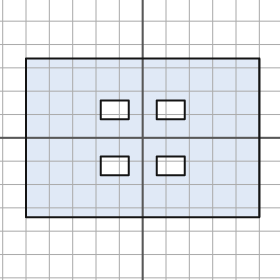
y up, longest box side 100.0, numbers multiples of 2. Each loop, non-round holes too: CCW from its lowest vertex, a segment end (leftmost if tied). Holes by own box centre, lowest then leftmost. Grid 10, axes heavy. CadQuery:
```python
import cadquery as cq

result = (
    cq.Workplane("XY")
    .moveTo(-50.0, -34.0)
    .lineTo(50.0, -34.0)
    .lineTo(50.0, 34.0)
    .lineTo(-50.0, 34.0)
    .close()
    .moveTo(-18.0, -16.0)
    .lineTo(-6.0, -16.0)
    .lineTo(-6.0, -8.0)
    .lineTo(-18.0, -8.0)
    .close()
    .moveTo(6.0, -16.0)
    .lineTo(18.0, -16.0)
    .lineTo(18.0, -8.0)
    .lineTo(6.0, -8.0)
    .close()
    .moveTo(-18.0, 8.0)
    .lineTo(-6.0, 8.0)
    .lineTo(-6.0, 16.0)
    .lineTo(-18.0, 16.0)
    .close()
    .moveTo(6.0, 8.0)
    .lineTo(18.0, 8.0)
    .lineTo(18.0, 16.0)
    .lineTo(6.0, 16.0)
    .close()
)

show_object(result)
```